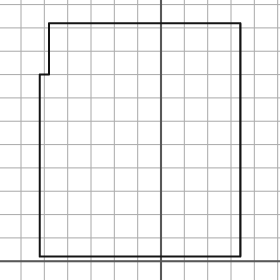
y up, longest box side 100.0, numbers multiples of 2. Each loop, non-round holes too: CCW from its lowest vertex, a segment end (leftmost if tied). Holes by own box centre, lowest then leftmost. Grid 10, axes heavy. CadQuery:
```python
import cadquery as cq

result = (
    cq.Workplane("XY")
    .moveTo(-52.0, 2.0)
    .lineTo(34.0, 2.0)
    .lineTo(34.0, 102.0)
    .lineTo(-48.0, 102.0)
    .lineTo(-48.0, 80.0)
    .lineTo(-52.0, 80.0)
    .close()
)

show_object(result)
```